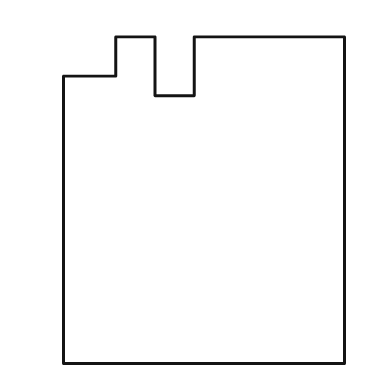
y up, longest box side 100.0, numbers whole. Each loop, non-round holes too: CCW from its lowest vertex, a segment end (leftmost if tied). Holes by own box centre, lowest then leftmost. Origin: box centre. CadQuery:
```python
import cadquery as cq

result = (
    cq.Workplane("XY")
    .moveTo(-43.0, -50.0)
    .lineTo(43.0, -50.0)
    .lineTo(43.0, 50.0)
    .lineTo(-3.0, 50.0)
    .lineTo(-3.0, 32.0)
    .lineTo(-15.0, 32.0)
    .lineTo(-15.0, 50.0)
    .lineTo(-27.0, 50.0)
    .lineTo(-27.0, 38.0)
    .lineTo(-43.0, 38.0)
    .close()
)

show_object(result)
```